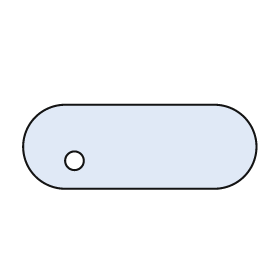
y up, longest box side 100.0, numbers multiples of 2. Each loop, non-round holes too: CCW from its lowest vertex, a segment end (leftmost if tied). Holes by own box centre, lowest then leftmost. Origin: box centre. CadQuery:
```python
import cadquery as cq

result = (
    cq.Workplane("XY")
    .moveTo(-32.0, -18.0)
    .lineTo(32.0, -18.0)
    .threePointArc((50.0, 0.0), (32.0, 18.0))
    .lineTo(-32.0, 18.0)
    .threePointArc((-50.0, 0.0), (-32.0, -18.0))
    .close()
    .moveTo(-28.0, -6.0)
    .circle(4.0)
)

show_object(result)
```